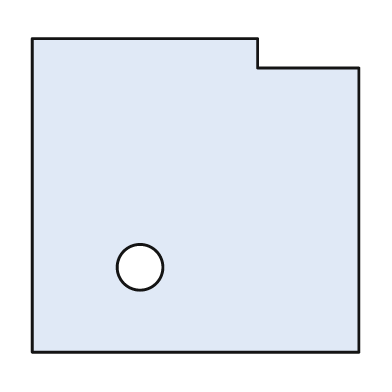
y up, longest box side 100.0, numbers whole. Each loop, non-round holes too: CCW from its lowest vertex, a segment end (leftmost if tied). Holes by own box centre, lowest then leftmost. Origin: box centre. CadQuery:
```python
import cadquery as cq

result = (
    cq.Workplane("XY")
    .moveTo(-50.0, -48.0)
    .lineTo(50.0, -48.0)
    .lineTo(50.0, 39.0)
    .lineTo(19.0, 39.0)
    .lineTo(19.0, 48.0)
    .lineTo(-50.0, 48.0)
    .close()
    .moveTo(-17.0, -22.0)
    .circle(7.0)
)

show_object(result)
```